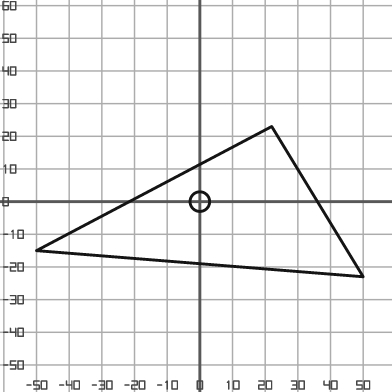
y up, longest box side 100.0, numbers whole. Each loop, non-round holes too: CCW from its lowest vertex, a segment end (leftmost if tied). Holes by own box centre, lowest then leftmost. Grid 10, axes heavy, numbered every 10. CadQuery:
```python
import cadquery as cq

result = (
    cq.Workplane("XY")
    .moveTo(50.0, -23.0)
    .lineTo(22.0, 23.0)
    .lineTo(-50.0, -15.0)
    .close()
    .moveTo(0.0, 0.0)
    .circle(3.0)
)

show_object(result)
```